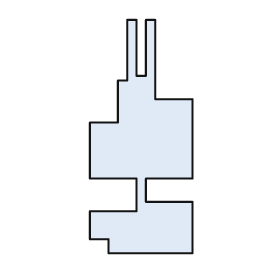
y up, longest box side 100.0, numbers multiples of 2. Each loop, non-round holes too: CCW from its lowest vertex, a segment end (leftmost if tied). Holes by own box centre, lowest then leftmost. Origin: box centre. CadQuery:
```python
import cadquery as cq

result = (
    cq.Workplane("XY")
    .moveTo(-14.0, -50.0)
    .lineTo(22.0, -50.0)
    .lineTo(22.0, -28.0)
    .lineTo(2.0, -28.0)
    .lineTo(2.0, -18.0)
    .lineTo(22.0, -18.0)
    .lineTo(22.0, 16.0)
    .lineTo(6.0, 16.0)
    .lineTo(6.0, 50.0)
    .lineTo(2.0, 50.0)
    .lineTo(2.0, 26.0)
    .lineTo(-2.0, 26.0)
    .lineTo(-2.0, 50.0)
    .lineTo(-6.0, 50.0)
    .lineTo(-6.0, 24.0)
    .lineTo(-10.0, 24.0)
    .lineTo(-10.0, 6.0)
    .lineTo(-22.0, 6.0)
    .lineTo(-22.0, -18.0)
    .lineTo(-2.0, -18.0)
    .lineTo(-2.0, -32.0)
    .lineTo(-22.0, -32.0)
    .lineTo(-22.0, -44.0)
    .lineTo(-14.0, -44.0)
    .close()
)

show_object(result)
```